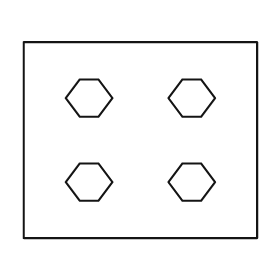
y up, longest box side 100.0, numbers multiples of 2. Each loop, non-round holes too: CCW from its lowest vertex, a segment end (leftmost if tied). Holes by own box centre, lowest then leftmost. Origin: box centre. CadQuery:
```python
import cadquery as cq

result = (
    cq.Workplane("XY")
    .moveTo(-50.0, -42.0)
    .lineTo(50.0, -42.0)
    .lineTo(50.0, 42.0)
    .lineTo(-50.0, 42.0)
    .close()
    .moveTo(-26.0, -26.0)
    .lineTo(-18.0, -26.0)
    .lineTo(-12.0, -18.0)
    .lineTo(-18.0, -10.0)
    .lineTo(-26.0, -10.0)
    .lineTo(-32.0, -18.0)
    .close()
    .moveTo(18.0, -26.0)
    .lineTo(26.0, -26.0)
    .lineTo(32.0, -18.0)
    .lineTo(26.0, -10.0)
    .lineTo(18.0, -10.0)
    .lineTo(12.0, -18.0)
    .close()
    .moveTo(-26.0, 10.0)
    .lineTo(-18.0, 10.0)
    .lineTo(-12.0, 18.0)
    .lineTo(-18.0, 26.0)
    .lineTo(-26.0, 26.0)
    .lineTo(-32.0, 18.0)
    .close()
    .moveTo(18.0, 10.0)
    .lineTo(26.0, 10.0)
    .lineTo(32.0, 18.0)
    .lineTo(26.0, 26.0)
    .lineTo(18.0, 26.0)
    .lineTo(12.0, 18.0)
    .close()
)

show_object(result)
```